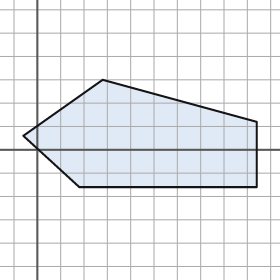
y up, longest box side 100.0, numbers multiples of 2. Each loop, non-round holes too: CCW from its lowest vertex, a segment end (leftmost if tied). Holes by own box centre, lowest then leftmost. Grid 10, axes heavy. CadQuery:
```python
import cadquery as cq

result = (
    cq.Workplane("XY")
    .moveTo(18.0, -16.0)
    .lineTo(94.0, -16.0)
    .lineTo(94.0, 12.0)
    .lineTo(28.0, 30.0)
    .lineTo(-6.0, 6.0)
    .close()
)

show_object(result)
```